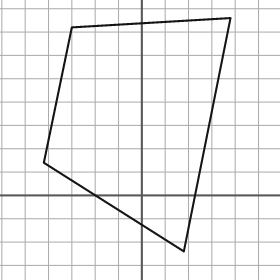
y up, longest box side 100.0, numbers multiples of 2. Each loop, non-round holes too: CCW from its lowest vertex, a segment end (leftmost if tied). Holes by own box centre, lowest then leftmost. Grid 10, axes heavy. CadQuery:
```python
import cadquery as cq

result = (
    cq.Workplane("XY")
    .moveTo(18.0, -24.0)
    .lineTo(38.0, 76.0)
    .lineTo(-30.0, 72.0)
    .lineTo(-42.0, 14.0)
    .close()
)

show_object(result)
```